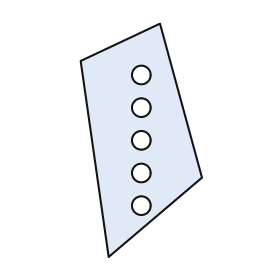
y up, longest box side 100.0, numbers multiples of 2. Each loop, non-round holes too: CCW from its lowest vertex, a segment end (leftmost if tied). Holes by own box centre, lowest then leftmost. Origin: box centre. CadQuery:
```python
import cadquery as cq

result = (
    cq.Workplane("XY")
    .moveTo(-14.0, -50.0)
    .lineTo(26.0, -16.0)
    .lineTo(8.0, 50.0)
    .lineTo(-26.0, 34.0)
    .close()
    .moveTo(0.0, -28.0)
    .circle(4.0)
    .moveTo(0.0, -14.0)
    .circle(4.0)
    .moveTo(0.0, 0.0)
    .circle(4.0)
    .moveTo(0.0, 14.0)
    .circle(4.0)
    .moveTo(0.0, 28.0)
    .circle(4.0)
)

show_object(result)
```